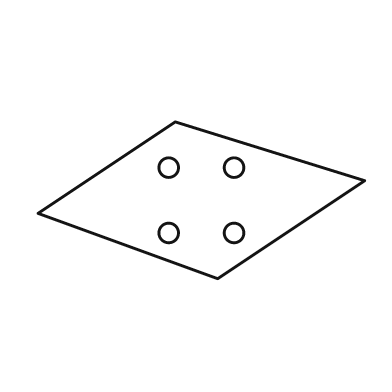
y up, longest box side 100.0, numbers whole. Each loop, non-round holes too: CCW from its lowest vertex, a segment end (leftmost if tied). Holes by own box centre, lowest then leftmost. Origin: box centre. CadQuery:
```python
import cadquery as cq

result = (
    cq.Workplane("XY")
    .moveTo(5.0, -24.0)
    .lineTo(50.0, 6.0)
    .lineTo(-8.0, 24.0)
    .lineTo(-50.0, -4.0)
    .close()
    .moveTo(-10.0, -10.0)
    .circle(3.0)
    .moveTo(10.0, -10.0)
    .circle(3.0)
    .moveTo(-10.0, 10.0)
    .circle(3.0)
    .moveTo(10.0, 10.0)
    .circle(3.0)
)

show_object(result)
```